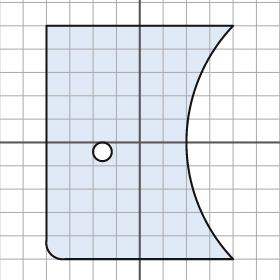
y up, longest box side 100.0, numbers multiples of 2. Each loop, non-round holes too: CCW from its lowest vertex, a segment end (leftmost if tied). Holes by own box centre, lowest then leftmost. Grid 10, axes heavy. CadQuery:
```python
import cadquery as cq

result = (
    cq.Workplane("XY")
    .moveTo(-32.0, -50.0)
    .lineTo(40.0, -50.0)
    .threePointArc((20.0, 0.0), (40.0, 50.0))
    .lineTo(-40.0, 50.0)
    .lineTo(-40.0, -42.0)
    .threePointArc((-38.0, -48.0), (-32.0, -50.0))
    .close()
    .moveTo(-16.0, -4.0)
    .circle(4.0)
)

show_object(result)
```